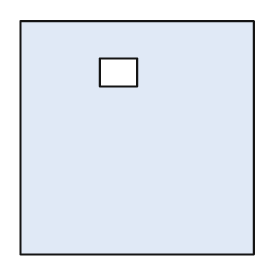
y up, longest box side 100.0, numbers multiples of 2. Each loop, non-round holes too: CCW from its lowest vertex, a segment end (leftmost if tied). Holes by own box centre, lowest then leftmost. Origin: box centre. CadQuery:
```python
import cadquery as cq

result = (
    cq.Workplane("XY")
    .moveTo(-50.0, -50.0)
    .lineTo(50.0, -50.0)
    .lineTo(50.0, 50.0)
    .lineTo(-50.0, 50.0)
    .close()
    .moveTo(-16.0, 22.0)
    .lineTo(0.0, 22.0)
    .lineTo(0.0, 34.0)
    .lineTo(-16.0, 34.0)
    .close()
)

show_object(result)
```